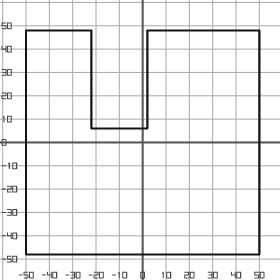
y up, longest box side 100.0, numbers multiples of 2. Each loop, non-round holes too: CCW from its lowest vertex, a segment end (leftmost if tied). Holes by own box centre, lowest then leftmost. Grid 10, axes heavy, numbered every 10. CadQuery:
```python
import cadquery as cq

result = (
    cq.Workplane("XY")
    .moveTo(-50.0, -48.0)
    .lineTo(50.0, -48.0)
    .lineTo(50.0, 48.0)
    .lineTo(2.0, 48.0)
    .lineTo(2.0, 6.0)
    .lineTo(-22.0, 6.0)
    .lineTo(-22.0, 48.0)
    .lineTo(-50.0, 48.0)
    .close()
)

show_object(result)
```